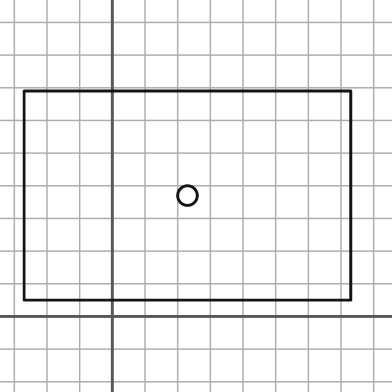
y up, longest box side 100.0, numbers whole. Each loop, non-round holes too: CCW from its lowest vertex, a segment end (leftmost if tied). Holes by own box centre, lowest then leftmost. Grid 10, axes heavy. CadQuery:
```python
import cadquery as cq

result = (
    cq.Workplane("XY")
    .moveTo(-27.0, 5.0)
    .lineTo(73.0, 5.0)
    .lineTo(73.0, 69.0)
    .lineTo(-27.0, 69.0)
    .close()
    .moveTo(23.0, 37.0)
    .circle(3.0)
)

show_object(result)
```